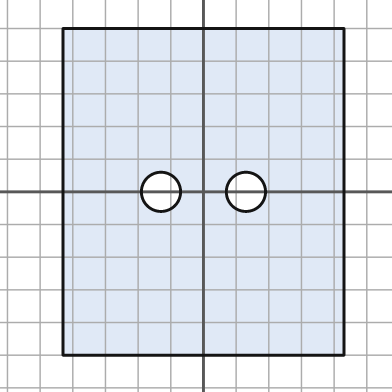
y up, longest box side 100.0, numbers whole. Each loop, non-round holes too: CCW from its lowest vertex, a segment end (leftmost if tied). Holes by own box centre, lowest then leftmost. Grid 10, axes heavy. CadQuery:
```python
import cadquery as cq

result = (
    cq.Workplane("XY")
    .moveTo(-43.0, -50.0)
    .lineTo(43.0, -50.0)
    .lineTo(43.0, 50.0)
    .lineTo(-43.0, 50.0)
    .close()
    .moveTo(-13.0, 0.0)
    .circle(6.0)
    .moveTo(13.0, 0.0)
    .circle(6.0)
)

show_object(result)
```